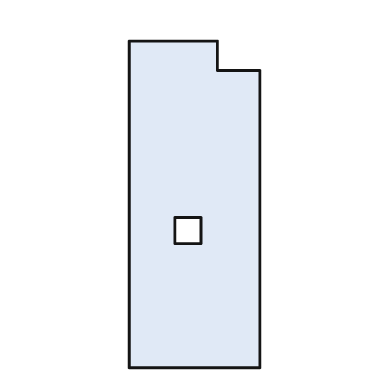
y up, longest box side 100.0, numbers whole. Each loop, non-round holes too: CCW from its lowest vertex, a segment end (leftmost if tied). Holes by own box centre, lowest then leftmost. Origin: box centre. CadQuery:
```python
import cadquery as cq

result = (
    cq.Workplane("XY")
    .moveTo(-20.0, -50.0)
    .lineTo(20.0, -50.0)
    .lineTo(20.0, 41.0)
    .lineTo(7.0, 41.0)
    .lineTo(7.0, 50.0)
    .lineTo(-20.0, 50.0)
    .close()
    .moveTo(-6.0, -12.0)
    .lineTo(2.0, -12.0)
    .lineTo(2.0, -4.0)
    .lineTo(-6.0, -4.0)
    .close()
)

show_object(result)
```